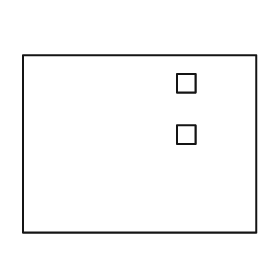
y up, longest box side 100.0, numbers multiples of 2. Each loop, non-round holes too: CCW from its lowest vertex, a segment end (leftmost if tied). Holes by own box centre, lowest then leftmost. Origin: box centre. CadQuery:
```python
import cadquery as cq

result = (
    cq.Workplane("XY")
    .moveTo(-50.0, -38.0)
    .lineTo(50.0, -38.0)
    .lineTo(50.0, 38.0)
    .lineTo(-50.0, 38.0)
    .close()
    .moveTo(16.0, 0.0)
    .lineTo(24.0, 0.0)
    .lineTo(24.0, 8.0)
    .lineTo(16.0, 8.0)
    .close()
    .moveTo(16.0, 22.0)
    .lineTo(24.0, 22.0)
    .lineTo(24.0, 30.0)
    .lineTo(16.0, 30.0)
    .close()
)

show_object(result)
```